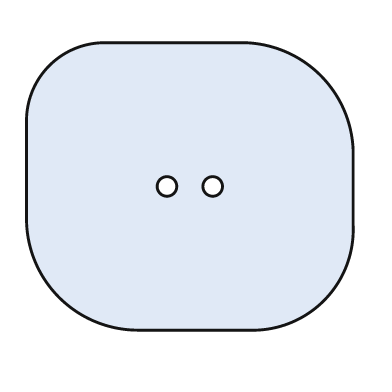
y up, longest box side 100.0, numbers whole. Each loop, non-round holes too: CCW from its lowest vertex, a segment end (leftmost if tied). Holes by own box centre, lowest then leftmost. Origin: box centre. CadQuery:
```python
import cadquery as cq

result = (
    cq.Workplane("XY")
    .moveTo(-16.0, -44.0)
    .lineTo(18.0, -44.0)
    .threePointArc((41.0, -35.0), (50.0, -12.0))
    .lineTo(50.0, 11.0)
    .threePointArc((40.0, 34.0), (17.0, 44.0))
    .lineTo(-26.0, 44.0)
    .threePointArc((-43.0, 37.0), (-50.0, 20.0))
    .lineTo(-50.0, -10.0)
    .threePointArc((-40.0, -34.0), (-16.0, -44.0))
    .close()
    .moveTo(-7.0, 0.0)
    .circle(3.0)
    .moveTo(7.0, 0.0)
    .circle(3.0)
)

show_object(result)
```